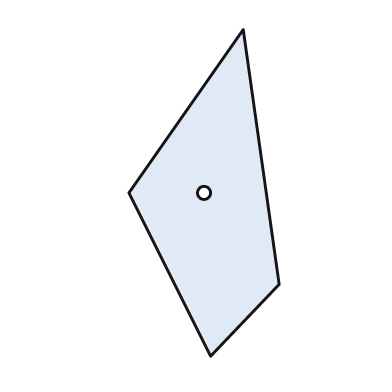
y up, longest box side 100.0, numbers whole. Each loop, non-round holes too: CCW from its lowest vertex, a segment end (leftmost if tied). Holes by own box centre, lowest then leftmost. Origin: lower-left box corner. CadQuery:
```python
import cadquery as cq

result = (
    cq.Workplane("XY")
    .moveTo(25.0, 0.0)
    .lineTo(46.0, 22.0)
    .lineTo(35.0, 100.0)
    .lineTo(0.0, 50.0)
    .close()
    .moveTo(23.0, 50.0)
    .circle(2.0)
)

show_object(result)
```